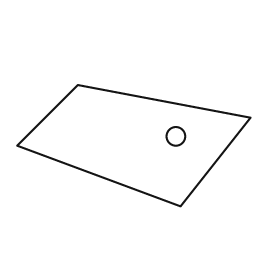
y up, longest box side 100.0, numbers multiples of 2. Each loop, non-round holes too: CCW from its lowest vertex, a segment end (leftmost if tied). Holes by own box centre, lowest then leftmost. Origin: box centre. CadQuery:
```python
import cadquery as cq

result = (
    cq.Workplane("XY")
    .moveTo(20.0, -26.0)
    .lineTo(50.0, 12.0)
    .lineTo(-24.0, 26.0)
    .lineTo(-50.0, 0.0)
    .close()
    .moveTo(18.0, 4.0)
    .circle(4.0)
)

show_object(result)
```